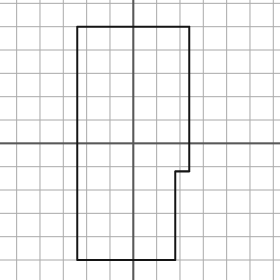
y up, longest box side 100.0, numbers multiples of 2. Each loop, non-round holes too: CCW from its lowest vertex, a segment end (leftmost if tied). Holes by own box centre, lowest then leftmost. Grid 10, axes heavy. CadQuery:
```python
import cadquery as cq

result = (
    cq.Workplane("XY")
    .moveTo(-24.0, -50.0)
    .lineTo(18.0, -50.0)
    .lineTo(18.0, -12.0)
    .lineTo(24.0, -12.0)
    .lineTo(24.0, 50.0)
    .lineTo(-24.0, 50.0)
    .close()
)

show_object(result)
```